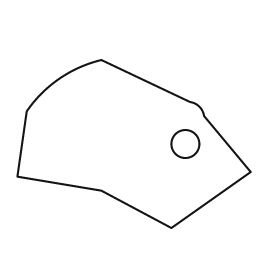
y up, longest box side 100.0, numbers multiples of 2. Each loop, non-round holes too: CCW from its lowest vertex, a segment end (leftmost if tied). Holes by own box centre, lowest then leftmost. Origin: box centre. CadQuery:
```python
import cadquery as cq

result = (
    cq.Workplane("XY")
    .moveTo(16.0, -36.0)
    .lineTo(50.0, -12.0)
    .lineTo(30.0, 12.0)
    .threePointArc((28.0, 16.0), (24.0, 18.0))
    .lineTo(-14.0, 36.0)
    .threePointArc((-32.0, 28.0), (-46.0, 14.0))
    .lineTo(-50.0, -14.0)
    .lineTo(-14.0, -20.0)
    .close()
    .moveTo(22.0, 0.0)
    .circle(6.0)
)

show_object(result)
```